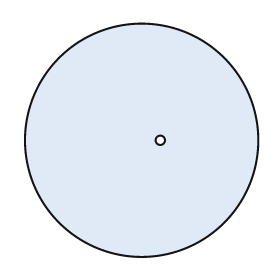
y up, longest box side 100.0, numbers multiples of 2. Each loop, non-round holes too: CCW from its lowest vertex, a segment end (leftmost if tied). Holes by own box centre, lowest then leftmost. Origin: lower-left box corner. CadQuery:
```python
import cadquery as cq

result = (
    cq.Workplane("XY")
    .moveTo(50.0, 50.0)
    .circle(50.0)
    .moveTo(58.0, 50.0)
    .circle(2.0)
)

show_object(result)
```